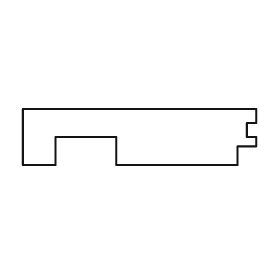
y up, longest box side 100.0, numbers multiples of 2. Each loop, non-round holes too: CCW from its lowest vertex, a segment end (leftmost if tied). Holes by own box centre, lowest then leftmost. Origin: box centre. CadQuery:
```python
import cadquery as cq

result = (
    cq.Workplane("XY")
    .moveTo(-50.0, -12.0)
    .lineTo(-36.0, -12.0)
    .lineTo(-36.0, 0.0)
    .lineTo(-10.0, 0.0)
    .lineTo(-10.0, -12.0)
    .lineTo(42.0, -12.0)
    .lineTo(42.0, -4.0)
    .lineTo(50.0, -4.0)
    .lineTo(50.0, 0.0)
    .lineTo(46.0, 0.0)
    .lineTo(46.0, 6.0)
    .lineTo(50.0, 6.0)
    .lineTo(50.0, 12.0)
    .lineTo(-50.0, 12.0)
    .close()
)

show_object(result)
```